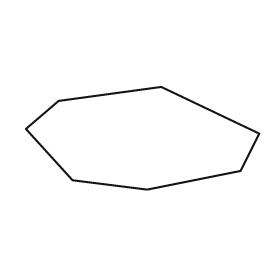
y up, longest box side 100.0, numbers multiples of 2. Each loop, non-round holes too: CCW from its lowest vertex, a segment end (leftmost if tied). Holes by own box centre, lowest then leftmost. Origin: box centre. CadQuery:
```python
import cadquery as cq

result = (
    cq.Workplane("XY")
    .moveTo(2.0, -22.0)
    .lineTo(42.0, -14.0)
    .lineTo(50.0, 2.0)
    .lineTo(8.0, 22.0)
    .lineTo(-36.0, 16.0)
    .lineTo(-50.0, 4.0)
    .lineTo(-30.0, -18.0)
    .close()
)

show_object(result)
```